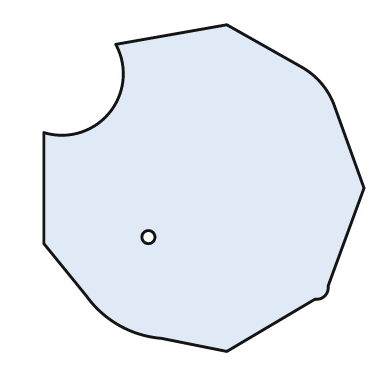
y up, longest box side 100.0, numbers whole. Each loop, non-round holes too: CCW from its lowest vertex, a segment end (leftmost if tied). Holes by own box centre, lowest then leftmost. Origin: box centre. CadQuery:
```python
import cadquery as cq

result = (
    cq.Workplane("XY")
    .moveTo(7.0, -50.0)
    .lineTo(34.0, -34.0)
    .threePointArc((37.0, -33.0), (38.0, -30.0))
    .lineTo(49.0, 0.0)
    .lineTo(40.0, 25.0)
    .threePointArc((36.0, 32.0), (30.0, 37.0))
    .lineTo(7.0, 50.0)
    .lineTo(-27.0, 44.0)
    .threePointArc((-29.0, 23.0), (-49.0, 17.0))
    .lineTo(-49.0, -17.0)
    .lineTo(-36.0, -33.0)
    .threePointArc((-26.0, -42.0), (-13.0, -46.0))
    .close()
    .moveTo(-17.0, -15.0)
    .circle(2.0)
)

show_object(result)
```